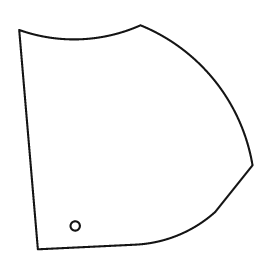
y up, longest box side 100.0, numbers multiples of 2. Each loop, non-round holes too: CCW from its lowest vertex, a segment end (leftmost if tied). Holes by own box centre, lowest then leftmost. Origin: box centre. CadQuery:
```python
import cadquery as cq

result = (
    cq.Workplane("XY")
    .moveTo(-42.0, -48.0)
    .lineTo(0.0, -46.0)
    .threePointArc((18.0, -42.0), (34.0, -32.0))
    .lineTo(50.0, -12.0)
    .threePointArc((34.0, 24.0), (2.0, 48.0))
    .threePointArc((-24.0, 42.0), (-50.0, 46.0))
    .close()
    .moveTo(-26.0, -38.0)
    .circle(2.0)
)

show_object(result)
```